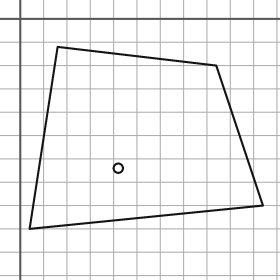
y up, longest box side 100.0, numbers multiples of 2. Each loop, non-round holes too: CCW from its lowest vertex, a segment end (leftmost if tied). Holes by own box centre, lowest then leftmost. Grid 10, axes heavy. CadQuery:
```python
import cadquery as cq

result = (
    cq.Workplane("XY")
    .moveTo(4.0, -90.0)
    .lineTo(104.0, -80.0)
    .lineTo(84.0, -20.0)
    .lineTo(16.0, -12.0)
    .close()
    .moveTo(42.0, -64.0)
    .circle(2.0)
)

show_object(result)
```